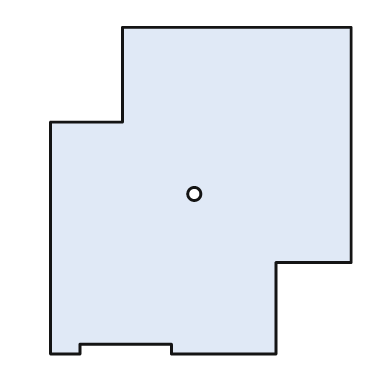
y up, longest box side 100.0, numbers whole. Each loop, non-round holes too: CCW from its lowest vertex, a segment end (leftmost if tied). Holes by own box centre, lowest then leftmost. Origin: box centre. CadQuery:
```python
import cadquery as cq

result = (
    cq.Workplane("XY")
    .moveTo(-46.0, -50.0)
    .lineTo(-37.0, -50.0)
    .lineTo(-37.0, -47.0)
    .lineTo(-9.0, -47.0)
    .lineTo(-9.0, -50.0)
    .lineTo(23.0, -50.0)
    .lineTo(23.0, -22.0)
    .lineTo(46.0, -22.0)
    .lineTo(46.0, 50.0)
    .lineTo(-24.0, 50.0)
    .lineTo(-24.0, 21.0)
    .lineTo(-46.0, 21.0)
    .close()
    .moveTo(-2.0, -1.0)
    .circle(2.0)
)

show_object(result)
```